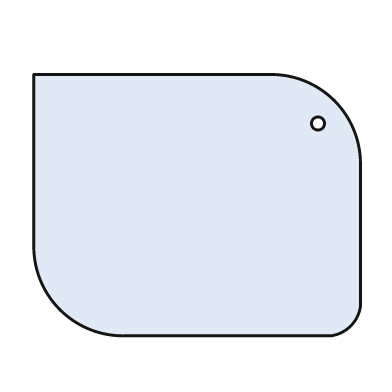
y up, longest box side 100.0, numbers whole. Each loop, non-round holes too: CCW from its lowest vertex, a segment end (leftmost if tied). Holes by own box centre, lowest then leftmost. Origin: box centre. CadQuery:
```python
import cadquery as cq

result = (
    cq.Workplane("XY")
    .moveTo(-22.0, -40.0)
    .lineTo(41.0, -40.0)
    .threePointArc((47.0, -37.0), (50.0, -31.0))
    .lineTo(50.0, 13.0)
    .threePointArc((42.0, 32.0), (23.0, 40.0))
    .lineTo(-50.0, 40.0)
    .lineTo(-50.0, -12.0)
    .threePointArc((-42.0, -32.0), (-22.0, -40.0))
    .close()
    .moveTo(37.0, 25.0)
    .circle(2.0)
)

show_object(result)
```